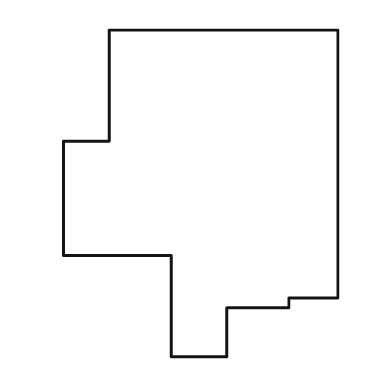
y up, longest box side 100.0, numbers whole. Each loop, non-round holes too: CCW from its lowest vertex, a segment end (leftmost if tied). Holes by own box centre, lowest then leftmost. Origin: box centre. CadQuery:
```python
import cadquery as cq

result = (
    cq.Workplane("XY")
    .moveTo(-9.0, -50.0)
    .lineTo(8.0, -50.0)
    .lineTo(8.0, -35.0)
    .lineTo(27.0, -35.0)
    .lineTo(27.0, -32.0)
    .lineTo(42.0, -32.0)
    .lineTo(42.0, 50.0)
    .lineTo(-28.0, 50.0)
    .lineTo(-28.0, 16.0)
    .lineTo(-42.0, 16.0)
    .lineTo(-42.0, -19.0)
    .lineTo(-9.0, -19.0)
    .close()
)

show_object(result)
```